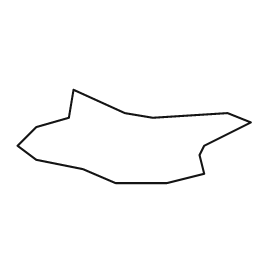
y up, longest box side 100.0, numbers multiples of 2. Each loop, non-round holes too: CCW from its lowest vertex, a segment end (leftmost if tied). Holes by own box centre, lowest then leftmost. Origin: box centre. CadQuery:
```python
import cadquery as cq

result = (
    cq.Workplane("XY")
    .moveTo(-8.0, -20.0)
    .lineTo(14.0, -20.0)
    .lineTo(30.0, -16.0)
    .lineTo(28.0, -8.0)
    .lineTo(30.0, -4.0)
    .lineTo(50.0, 6.0)
    .lineTo(40.0, 10.0)
    .lineTo(8.0, 8.0)
    .lineTo(-4.0, 10.0)
    .lineTo(-26.0, 20.0)
    .lineTo(-28.0, 8.0)
    .lineTo(-42.0, 4.0)
    .lineTo(-50.0, -4.0)
    .lineTo(-42.0, -10.0)
    .lineTo(-22.0, -14.0)
    .close()
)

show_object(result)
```